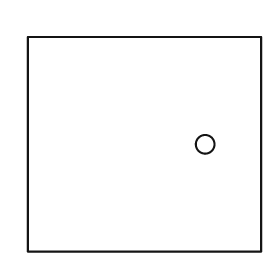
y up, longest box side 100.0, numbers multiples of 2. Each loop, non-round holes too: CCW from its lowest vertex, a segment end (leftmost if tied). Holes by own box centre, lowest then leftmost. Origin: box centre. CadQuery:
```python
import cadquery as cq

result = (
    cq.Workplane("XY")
    .moveTo(-50.0, -46.0)
    .lineTo(50.0, -46.0)
    .lineTo(50.0, 46.0)
    .lineTo(-50.0, 46.0)
    .close()
    .moveTo(26.0, 0.0)
    .circle(4.0)
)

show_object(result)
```